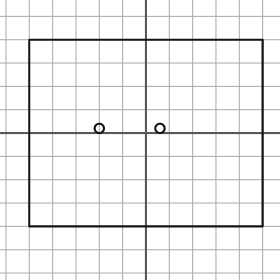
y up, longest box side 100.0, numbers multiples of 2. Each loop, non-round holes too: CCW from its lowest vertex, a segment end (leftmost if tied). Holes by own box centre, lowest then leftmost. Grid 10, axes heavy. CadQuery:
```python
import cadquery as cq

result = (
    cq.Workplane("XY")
    .moveTo(-50.0, -40.0)
    .lineTo(50.0, -40.0)
    .lineTo(50.0, 40.0)
    .lineTo(-50.0, 40.0)
    .close()
    .moveTo(-20.0, 2.0)
    .circle(2.0)
    .moveTo(6.0, 2.0)
    .circle(2.0)
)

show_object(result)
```